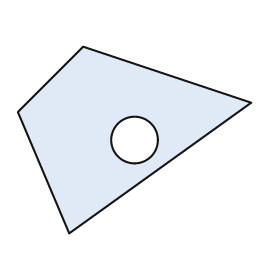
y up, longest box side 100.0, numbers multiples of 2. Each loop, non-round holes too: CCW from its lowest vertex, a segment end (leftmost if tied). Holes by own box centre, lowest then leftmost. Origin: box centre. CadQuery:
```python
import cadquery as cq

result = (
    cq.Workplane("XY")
    .moveTo(-28.0, -40.0)
    .lineTo(50.0, 16.0)
    .lineTo(-22.0, 40.0)
    .lineTo(-50.0, 12.0)
    .close()
    .moveTo(0.0, 0.0)
    .circle(10.0)
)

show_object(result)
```